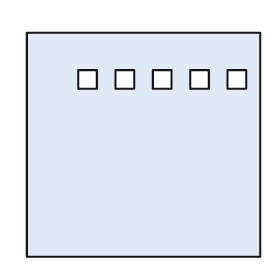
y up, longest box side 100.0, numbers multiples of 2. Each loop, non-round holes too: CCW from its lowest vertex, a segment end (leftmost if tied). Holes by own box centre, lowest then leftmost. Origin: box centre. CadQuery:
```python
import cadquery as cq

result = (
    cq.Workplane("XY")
    .moveTo(-50.0, -48.0)
    .lineTo(50.0, -48.0)
    .lineTo(50.0, 48.0)
    .lineTo(-50.0, 48.0)
    .close()
    .moveTo(-28.0, 24.0)
    .lineTo(-20.0, 24.0)
    .lineTo(-20.0, 32.0)
    .lineTo(-28.0, 32.0)
    .close()
    .moveTo(-12.0, 24.0)
    .lineTo(-4.0, 24.0)
    .lineTo(-4.0, 32.0)
    .lineTo(-12.0, 32.0)
    .close()
    .moveTo(4.0, 24.0)
    .lineTo(12.0, 24.0)
    .lineTo(12.0, 32.0)
    .lineTo(4.0, 32.0)
    .close()
    .moveTo(20.0, 24.0)
    .lineTo(28.0, 24.0)
    .lineTo(28.0, 32.0)
    .lineTo(20.0, 32.0)
    .close()
    .moveTo(36.0, 24.0)
    .lineTo(44.0, 24.0)
    .lineTo(44.0, 32.0)
    .lineTo(36.0, 32.0)
    .close()
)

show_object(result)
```